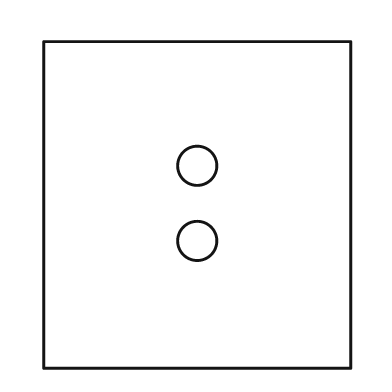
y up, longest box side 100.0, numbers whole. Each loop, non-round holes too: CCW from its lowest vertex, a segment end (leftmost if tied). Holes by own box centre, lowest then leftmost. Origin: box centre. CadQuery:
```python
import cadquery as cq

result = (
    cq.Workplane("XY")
    .moveTo(-47.0, -50.0)
    .lineTo(47.0, -50.0)
    .lineTo(47.0, 50.0)
    .lineTo(-47.0, 50.0)
    .close()
    .moveTo(0.0, -11.0)
    .circle(6.0)
    .moveTo(0.0, 12.0)
    .circle(6.0)
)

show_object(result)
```